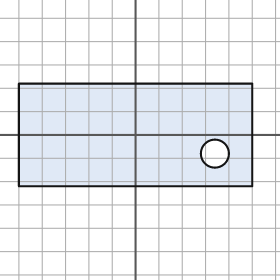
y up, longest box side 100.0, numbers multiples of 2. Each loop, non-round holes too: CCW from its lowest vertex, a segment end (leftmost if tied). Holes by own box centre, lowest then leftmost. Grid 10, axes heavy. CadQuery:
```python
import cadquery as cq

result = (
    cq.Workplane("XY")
    .moveTo(-50.0, -22.0)
    .lineTo(50.0, -22.0)
    .lineTo(50.0, 22.0)
    .lineTo(-50.0, 22.0)
    .close()
    .moveTo(34.0, -8.0)
    .circle(6.0)
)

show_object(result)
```